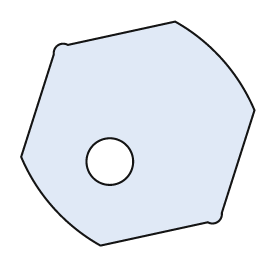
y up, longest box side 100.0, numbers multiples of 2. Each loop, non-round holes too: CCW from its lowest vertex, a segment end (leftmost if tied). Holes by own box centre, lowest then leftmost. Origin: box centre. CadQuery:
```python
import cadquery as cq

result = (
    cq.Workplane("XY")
    .moveTo(-16.0, -48.0)
    .lineTo(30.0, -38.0)
    .threePointArc((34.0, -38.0), (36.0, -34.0))
    .lineTo(50.0, 10.0)
    .threePointArc((36.0, 32.0), (16.0, 48.0))
    .lineTo(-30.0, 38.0)
    .threePointArc((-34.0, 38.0), (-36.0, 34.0))
    .lineTo(-50.0, -10.0)
    .threePointArc((-36.0, -32.0), (-16.0, -48.0))
    .close()
    .moveTo(-12.0, -12.0)
    .circle(10.0)
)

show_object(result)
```